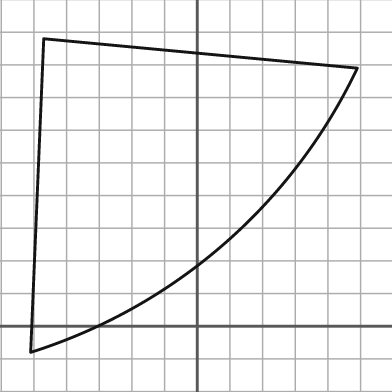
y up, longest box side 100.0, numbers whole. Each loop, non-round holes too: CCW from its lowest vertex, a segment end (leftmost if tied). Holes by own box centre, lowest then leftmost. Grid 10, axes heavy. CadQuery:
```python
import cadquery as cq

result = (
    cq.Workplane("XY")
    .moveTo(-51.0, -8.0)
    .threePointArc((8.0, 25.0), (49.0, 79.0))
    .lineTo(-47.0, 88.0)
    .close()
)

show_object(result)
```